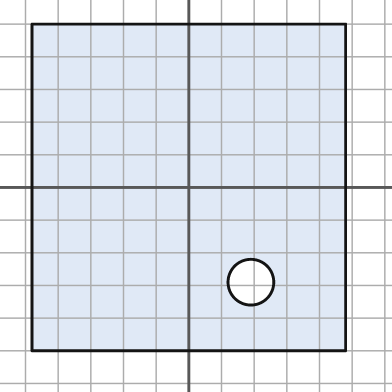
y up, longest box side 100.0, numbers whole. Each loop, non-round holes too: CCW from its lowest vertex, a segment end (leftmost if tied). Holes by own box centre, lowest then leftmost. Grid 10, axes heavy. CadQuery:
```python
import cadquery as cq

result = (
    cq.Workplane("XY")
    .moveTo(-48.0, -50.0)
    .lineTo(48.0, -50.0)
    .lineTo(48.0, 50.0)
    .lineTo(-48.0, 50.0)
    .close()
    .moveTo(19.0, -29.0)
    .circle(7.0)
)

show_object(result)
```